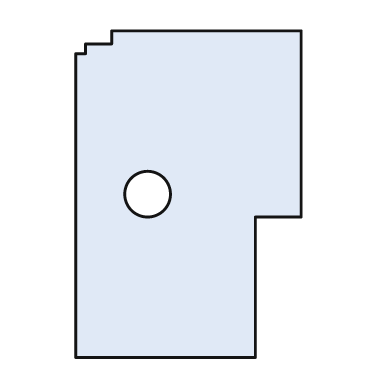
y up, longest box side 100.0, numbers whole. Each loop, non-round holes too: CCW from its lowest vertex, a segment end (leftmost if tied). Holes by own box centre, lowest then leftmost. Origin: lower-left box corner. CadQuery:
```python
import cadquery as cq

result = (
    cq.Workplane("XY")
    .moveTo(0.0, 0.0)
    .lineTo(55.0, 0.0)
    .lineTo(55.0, 43.0)
    .lineTo(69.0, 43.0)
    .lineTo(69.0, 100.0)
    .lineTo(11.0, 100.0)
    .lineTo(11.0, 96.0)
    .lineTo(3.0, 96.0)
    .lineTo(3.0, 93.0)
    .lineTo(0.0, 93.0)
    .close()
    .moveTo(22.0, 50.0)
    .circle(7.0)
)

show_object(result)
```